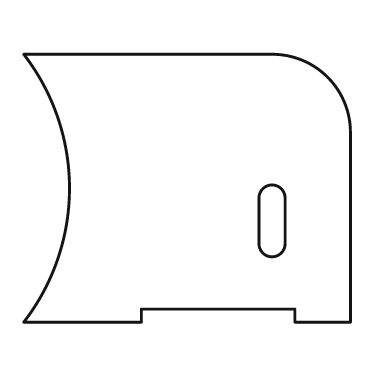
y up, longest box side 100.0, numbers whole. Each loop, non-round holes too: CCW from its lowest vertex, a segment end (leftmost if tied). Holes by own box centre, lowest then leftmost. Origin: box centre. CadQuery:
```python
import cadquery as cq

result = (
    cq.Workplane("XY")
    .moveTo(-50.0, -41.0)
    .lineTo(-14.0, -41.0)
    .lineTo(-14.0, -37.0)
    .lineTo(33.0, -37.0)
    .lineTo(33.0, -41.0)
    .lineTo(50.0, -41.0)
    .lineTo(50.0, 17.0)
    .threePointArc((43.0, 34.0), (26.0, 41.0))
    .lineTo(-50.0, 41.0)
    .threePointArc((-36.0, 0.0), (-50.0, -41.0))
    .close()
    .moveTo(22.0, -17.0)
    .threePointArc((26.0, -21.0), (30.0, -17.0))
    .lineTo(30.0, -3.0)
    .threePointArc((26.0, 1.0), (22.0, -3.0))
    .close()
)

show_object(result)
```